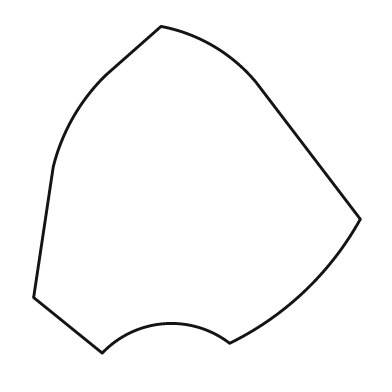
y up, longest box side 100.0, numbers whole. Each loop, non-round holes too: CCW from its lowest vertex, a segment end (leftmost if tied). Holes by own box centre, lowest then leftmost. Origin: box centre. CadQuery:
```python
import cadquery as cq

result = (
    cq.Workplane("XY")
    .moveTo(-29.0, -50.0)
    .threePointArc((-10.0, -41.0), (10.0, -47.0))
    .threePointArc((33.0, -31.0), (50.0, -9.0))
    .lineTo(18.0, 33.0)
    .threePointArc((5.0, 44.0), (-11.0, 50.0))
    .lineTo(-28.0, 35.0)
    .threePointArc((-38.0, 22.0), (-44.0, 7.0))
    .lineTo(-50.0, -33.0)
    .close()
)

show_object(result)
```